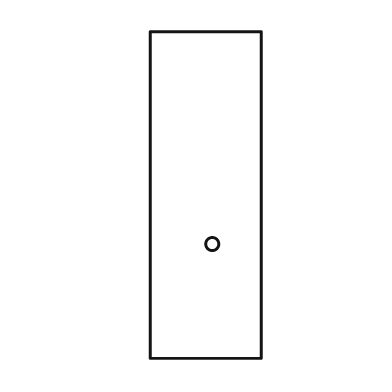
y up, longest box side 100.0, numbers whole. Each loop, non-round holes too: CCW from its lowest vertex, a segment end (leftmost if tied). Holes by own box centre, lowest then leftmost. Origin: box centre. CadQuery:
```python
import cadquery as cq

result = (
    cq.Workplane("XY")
    .moveTo(-17.0, -50.0)
    .lineTo(17.0, -50.0)
    .lineTo(17.0, 50.0)
    .lineTo(-17.0, 50.0)
    .close()
    .moveTo(2.0, -15.0)
    .circle(2.0)
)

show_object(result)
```